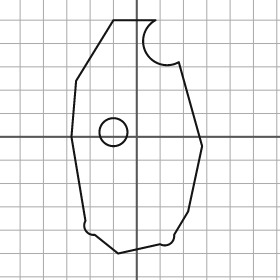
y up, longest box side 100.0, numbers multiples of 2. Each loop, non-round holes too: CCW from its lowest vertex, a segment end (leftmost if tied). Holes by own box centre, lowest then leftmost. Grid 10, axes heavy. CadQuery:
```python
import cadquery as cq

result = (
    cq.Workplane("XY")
    .moveTo(-8.0, -50.0)
    .lineTo(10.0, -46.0)
    .threePointArc((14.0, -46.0), (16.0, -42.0))
    .lineTo(22.0, -32.0)
    .lineTo(28.0, -4.0)
    .lineTo(18.0, 32.0)
    .threePointArc((4.0, 36.0), (8.0, 50.0))
    .lineTo(-10.0, 50.0)
    .lineTo(-26.0, 24.0)
    .lineTo(-28.0, 0.0)
    .lineTo(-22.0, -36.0)
    .threePointArc((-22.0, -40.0), (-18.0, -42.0))
    .close()
    .moveTo(-10.0, 2.0)
    .circle(6.0)
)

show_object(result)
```